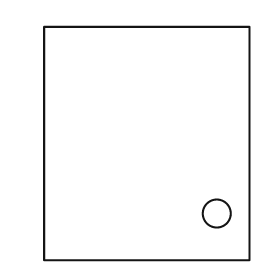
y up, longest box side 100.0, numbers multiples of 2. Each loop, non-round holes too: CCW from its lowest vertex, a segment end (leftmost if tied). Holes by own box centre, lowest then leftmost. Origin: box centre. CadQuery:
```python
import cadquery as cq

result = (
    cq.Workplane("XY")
    .moveTo(-44.0, -50.0)
    .lineTo(44.0, -50.0)
    .lineTo(44.0, 50.0)
    .lineTo(-44.0, 50.0)
    .close()
    .moveTo(30.0, -30.0)
    .circle(6.0)
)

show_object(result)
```